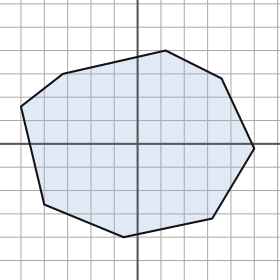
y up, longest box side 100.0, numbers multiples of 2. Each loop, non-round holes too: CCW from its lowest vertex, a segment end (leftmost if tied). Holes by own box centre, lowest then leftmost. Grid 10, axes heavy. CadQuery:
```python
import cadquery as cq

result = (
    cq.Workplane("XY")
    .moveTo(-6.0, -40.0)
    .lineTo(32.0, -32.0)
    .lineTo(50.0, -2.0)
    .lineTo(36.0, 28.0)
    .lineTo(12.0, 40.0)
    .lineTo(-32.0, 30.0)
    .lineTo(-50.0, 16.0)
    .lineTo(-40.0, -26.0)
    .close()
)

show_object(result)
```